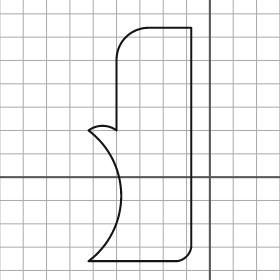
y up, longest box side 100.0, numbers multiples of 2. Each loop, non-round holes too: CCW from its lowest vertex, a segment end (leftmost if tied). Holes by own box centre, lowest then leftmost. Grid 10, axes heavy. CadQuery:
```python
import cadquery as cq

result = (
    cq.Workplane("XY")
    .moveTo(-52.0, -36.0)
    .lineTo(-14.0, -36.0)
    .threePointArc((-10.0, -34.0), (-8.0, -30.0))
    .lineTo(-8.0, 64.0)
    .lineTo(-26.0, 64.0)
    .threePointArc((-36.0, 60.0), (-40.0, 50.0))
    .lineTo(-40.0, 20.0)
    .threePointArc((-46.0, 22.0), (-52.0, 20.0))
    .threePointArc((-38.0, -8.0), (-52.0, -36.0))
    .close()
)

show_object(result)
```